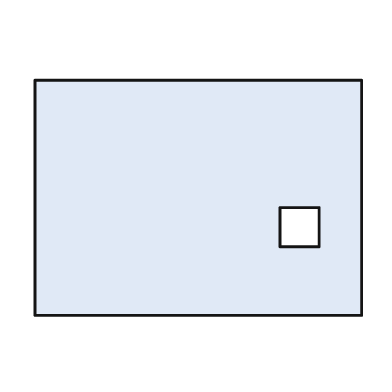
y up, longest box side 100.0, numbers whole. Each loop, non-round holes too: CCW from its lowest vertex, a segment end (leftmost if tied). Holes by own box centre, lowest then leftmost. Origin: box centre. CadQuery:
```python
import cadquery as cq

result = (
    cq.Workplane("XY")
    .moveTo(-50.0, -36.0)
    .lineTo(50.0, -36.0)
    .lineTo(50.0, 36.0)
    .lineTo(-50.0, 36.0)
    .close()
    .moveTo(25.0, -15.0)
    .lineTo(37.0, -15.0)
    .lineTo(37.0, -3.0)
    .lineTo(25.0, -3.0)
    .close()
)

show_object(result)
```